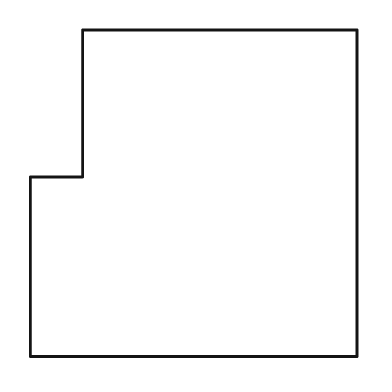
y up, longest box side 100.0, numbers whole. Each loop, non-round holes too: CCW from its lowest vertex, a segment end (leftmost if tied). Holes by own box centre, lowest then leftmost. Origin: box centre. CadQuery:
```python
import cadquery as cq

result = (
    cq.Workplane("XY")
    .moveTo(-50.0, -50.0)
    .lineTo(50.0, -50.0)
    .lineTo(50.0, 50.0)
    .lineTo(-34.0, 50.0)
    .lineTo(-34.0, 5.0)
    .lineTo(-50.0, 5.0)
    .close()
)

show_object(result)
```